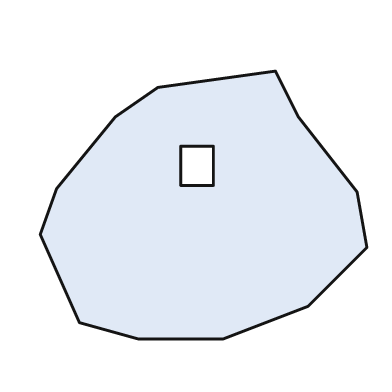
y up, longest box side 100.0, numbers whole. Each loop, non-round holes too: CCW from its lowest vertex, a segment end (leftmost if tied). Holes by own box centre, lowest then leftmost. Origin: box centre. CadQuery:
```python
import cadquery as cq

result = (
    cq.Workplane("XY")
    .moveTo(-20.0, -41.0)
    .lineTo(6.0, -41.0)
    .lineTo(32.0, -31.0)
    .lineTo(50.0, -13.0)
    .lineTo(47.0, 4.0)
    .lineTo(29.0, 27.0)
    .lineTo(22.0, 41.0)
    .lineTo(-14.0, 36.0)
    .lineTo(-27.0, 27.0)
    .lineTo(-45.0, 5.0)
    .lineTo(-50.0, -9.0)
    .lineTo(-38.0, -36.0)
    .close()
    .moveTo(-7.0, 6.0)
    .lineTo(3.0, 6.0)
    .lineTo(3.0, 18.0)
    .lineTo(-7.0, 18.0)
    .close()
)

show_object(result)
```